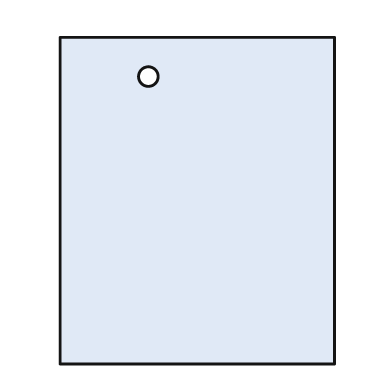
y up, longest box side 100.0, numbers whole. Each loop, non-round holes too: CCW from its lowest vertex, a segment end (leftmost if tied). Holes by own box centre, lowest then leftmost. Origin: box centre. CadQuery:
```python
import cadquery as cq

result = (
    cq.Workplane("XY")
    .moveTo(-42.0, -50.0)
    .lineTo(42.0, -50.0)
    .lineTo(42.0, 50.0)
    .lineTo(-42.0, 50.0)
    .close()
    .moveTo(-15.0, 38.0)
    .circle(3.0)
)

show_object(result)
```